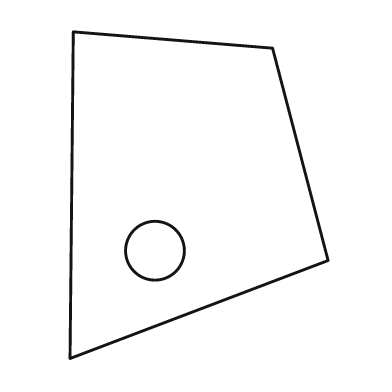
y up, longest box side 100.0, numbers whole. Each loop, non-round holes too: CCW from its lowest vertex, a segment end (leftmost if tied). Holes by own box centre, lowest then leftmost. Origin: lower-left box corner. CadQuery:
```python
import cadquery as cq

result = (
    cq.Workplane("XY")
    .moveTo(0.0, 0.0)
    .lineTo(79.0, 30.0)
    .lineTo(62.0, 95.0)
    .lineTo(1.0, 100.0)
    .close()
    .moveTo(26.0, 33.0)
    .circle(9.0)
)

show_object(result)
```